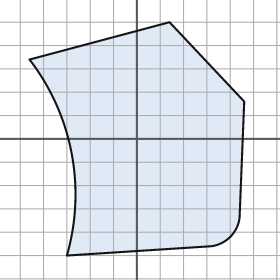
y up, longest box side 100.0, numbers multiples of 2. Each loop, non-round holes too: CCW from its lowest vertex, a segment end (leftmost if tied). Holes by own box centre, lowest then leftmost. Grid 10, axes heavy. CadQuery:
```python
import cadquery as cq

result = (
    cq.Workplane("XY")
    .moveTo(-30.0, -50.0)
    .lineTo(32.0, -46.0)
    .threePointArc((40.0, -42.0), (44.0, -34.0))
    .lineTo(46.0, 16.0)
    .lineTo(14.0, 50.0)
    .lineTo(-46.0, 34.0)
    .threePointArc((-28.0, -6.0), (-30.0, -50.0))
    .close()
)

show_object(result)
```